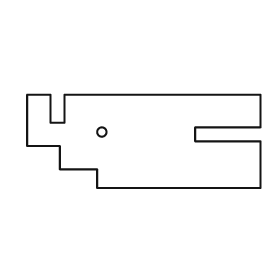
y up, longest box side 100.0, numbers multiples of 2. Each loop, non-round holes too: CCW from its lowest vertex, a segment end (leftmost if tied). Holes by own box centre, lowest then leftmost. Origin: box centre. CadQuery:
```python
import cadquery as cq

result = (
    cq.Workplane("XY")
    .moveTo(-20.0, -20.0)
    .lineTo(50.0, -20.0)
    .lineTo(50.0, 0.0)
    .lineTo(22.0, 0.0)
    .lineTo(22.0, 6.0)
    .lineTo(50.0, 6.0)
    .lineTo(50.0, 20.0)
    .lineTo(-34.0, 20.0)
    .lineTo(-34.0, 8.0)
    .lineTo(-40.0, 8.0)
    .lineTo(-40.0, 20.0)
    .lineTo(-50.0, 20.0)
    .lineTo(-50.0, -2.0)
    .lineTo(-36.0, -2.0)
    .lineTo(-36.0, -12.0)
    .lineTo(-20.0, -12.0)
    .close()
    .moveTo(-18.0, 4.0)
    .circle(2.0)
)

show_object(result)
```